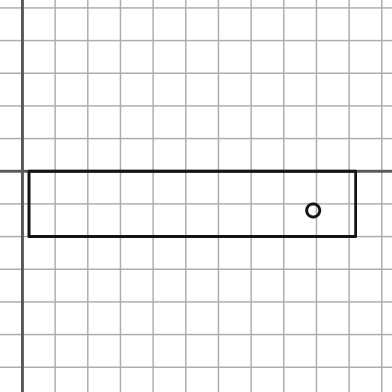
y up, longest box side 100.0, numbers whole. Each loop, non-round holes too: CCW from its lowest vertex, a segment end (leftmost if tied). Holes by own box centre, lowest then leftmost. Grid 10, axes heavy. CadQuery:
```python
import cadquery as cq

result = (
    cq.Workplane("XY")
    .moveTo(2.0, -20.0)
    .lineTo(102.0, -20.0)
    .lineTo(102.0, 0.0)
    .lineTo(2.0, 0.0)
    .close()
    .moveTo(89.0, -12.0)
    .circle(2.0)
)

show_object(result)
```